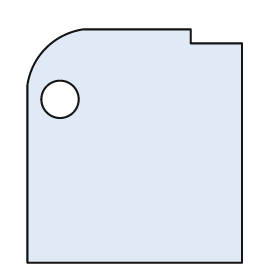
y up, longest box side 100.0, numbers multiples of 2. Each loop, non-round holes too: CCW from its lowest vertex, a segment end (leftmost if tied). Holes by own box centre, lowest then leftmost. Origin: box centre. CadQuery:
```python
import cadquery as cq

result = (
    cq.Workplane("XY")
    .moveTo(-46.0, -50.0)
    .lineTo(46.0, -50.0)
    .lineTo(46.0, 44.0)
    .lineTo(24.0, 44.0)
    .lineTo(24.0, 50.0)
    .lineTo(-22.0, 50.0)
    .threePointArc((-38.0, 42.0), (-46.0, 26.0))
    .close()
    .moveTo(-32.0, 20.0)
    .circle(8.0)
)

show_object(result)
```